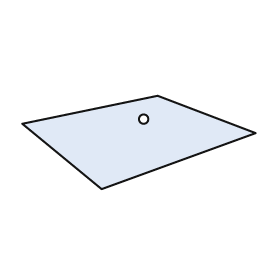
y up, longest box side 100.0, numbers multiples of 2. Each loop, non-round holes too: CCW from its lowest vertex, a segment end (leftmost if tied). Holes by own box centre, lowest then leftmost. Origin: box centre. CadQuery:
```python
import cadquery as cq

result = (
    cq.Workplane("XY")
    .moveTo(-16.0, -20.0)
    .lineTo(50.0, 4.0)
    .lineTo(8.0, 20.0)
    .lineTo(-50.0, 8.0)
    .close()
    .moveTo(2.0, 10.0)
    .circle(2.0)
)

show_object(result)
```